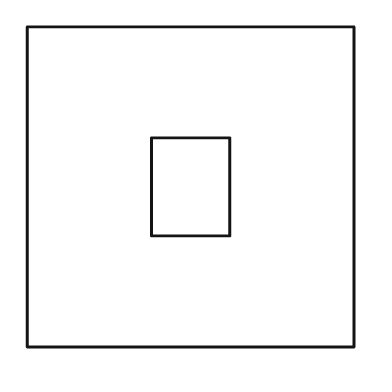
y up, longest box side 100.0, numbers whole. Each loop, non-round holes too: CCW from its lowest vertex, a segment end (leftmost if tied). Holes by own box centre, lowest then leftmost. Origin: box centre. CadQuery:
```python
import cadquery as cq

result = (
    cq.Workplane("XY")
    .moveTo(-50.0, -49.0)
    .lineTo(50.0, -49.0)
    .lineTo(50.0, 49.0)
    .lineTo(-50.0, 49.0)
    .close()
    .moveTo(-12.0, -15.0)
    .lineTo(12.0, -15.0)
    .lineTo(12.0, 15.0)
    .lineTo(-12.0, 15.0)
    .close()
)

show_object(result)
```